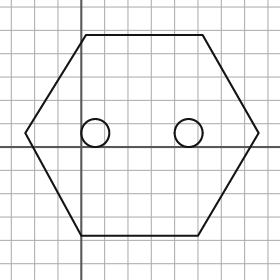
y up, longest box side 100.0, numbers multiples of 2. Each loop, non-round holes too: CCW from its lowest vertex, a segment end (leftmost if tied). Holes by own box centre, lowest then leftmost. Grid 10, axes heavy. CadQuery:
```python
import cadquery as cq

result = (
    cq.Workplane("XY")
    .moveTo(0.0, -38.0)
    .lineTo(50.0, -38.0)
    .lineTo(76.0, 6.0)
    .lineTo(52.0, 48.0)
    .lineTo(2.0, 48.0)
    .lineTo(-24.0, 6.0)
    .close()
    .moveTo(6.0, 6.0)
    .circle(6.0)
    .moveTo(46.0, 6.0)
    .circle(6.0)
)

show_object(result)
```